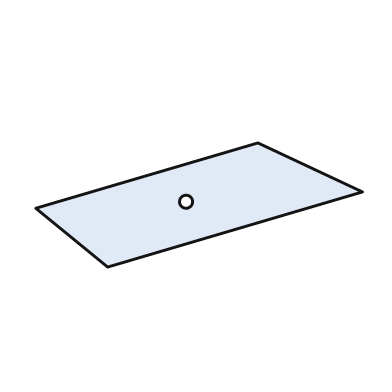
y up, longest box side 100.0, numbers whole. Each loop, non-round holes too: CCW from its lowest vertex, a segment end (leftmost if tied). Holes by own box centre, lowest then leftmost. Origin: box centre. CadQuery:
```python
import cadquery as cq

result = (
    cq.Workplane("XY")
    .moveTo(-28.0, -19.0)
    .lineTo(50.0, 4.0)
    .lineTo(18.0, 19.0)
    .lineTo(-50.0, -1.0)
    .close()
    .moveTo(-4.0, 1.0)
    .circle(2.0)
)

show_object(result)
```